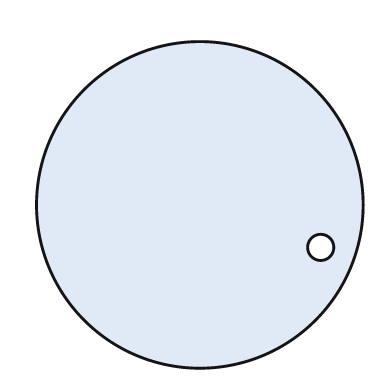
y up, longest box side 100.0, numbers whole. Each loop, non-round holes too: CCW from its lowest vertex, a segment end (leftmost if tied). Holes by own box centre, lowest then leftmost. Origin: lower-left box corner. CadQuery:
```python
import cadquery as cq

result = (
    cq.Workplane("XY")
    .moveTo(50.0, 50.0)
    .circle(50.0)
    .moveTo(87.0, 37.0)
    .circle(4.0)
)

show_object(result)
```